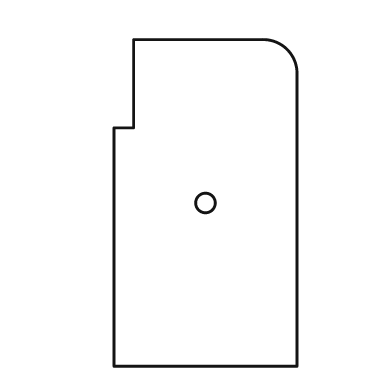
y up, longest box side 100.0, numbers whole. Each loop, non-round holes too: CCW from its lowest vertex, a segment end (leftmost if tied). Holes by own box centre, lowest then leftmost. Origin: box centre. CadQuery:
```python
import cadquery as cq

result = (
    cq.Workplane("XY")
    .moveTo(-28.0, -50.0)
    .lineTo(28.0, -50.0)
    .lineTo(28.0, 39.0)
    .threePointArc((25.0, 47.0), (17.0, 50.0))
    .lineTo(-22.0, 50.0)
    .lineTo(-22.0, 23.0)
    .lineTo(-28.0, 23.0)
    .close()
    .moveTo(0.0, 0.0)
    .circle(3.0)
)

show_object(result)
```